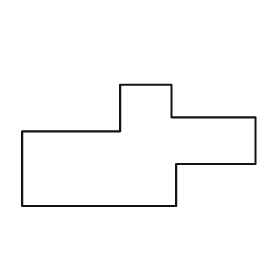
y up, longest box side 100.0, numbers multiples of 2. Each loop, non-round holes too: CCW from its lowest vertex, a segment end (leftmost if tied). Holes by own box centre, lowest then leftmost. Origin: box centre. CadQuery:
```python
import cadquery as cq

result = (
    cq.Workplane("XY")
    .moveTo(-50.0, -26.0)
    .lineTo(16.0, -26.0)
    .lineTo(16.0, -8.0)
    .lineTo(50.0, -8.0)
    .lineTo(50.0, 12.0)
    .lineTo(14.0, 12.0)
    .lineTo(14.0, 26.0)
    .lineTo(-8.0, 26.0)
    .lineTo(-8.0, 6.0)
    .lineTo(-50.0, 6.0)
    .close()
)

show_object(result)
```